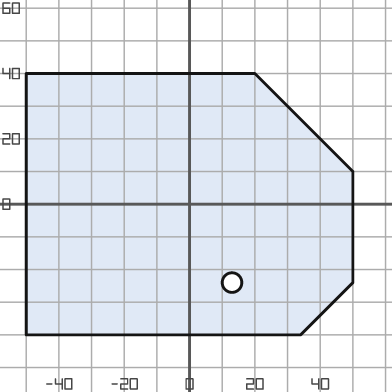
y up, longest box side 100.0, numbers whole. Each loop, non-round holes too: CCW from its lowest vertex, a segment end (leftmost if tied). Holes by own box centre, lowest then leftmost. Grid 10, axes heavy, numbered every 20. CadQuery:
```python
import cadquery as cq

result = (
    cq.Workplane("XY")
    .moveTo(-50.0, -40.0)
    .lineTo(34.0, -40.0)
    .lineTo(50.0, -24.0)
    .lineTo(50.0, 10.0)
    .lineTo(20.0, 40.0)
    .lineTo(-50.0, 40.0)
    .close()
    .moveTo(13.0, -24.0)
    .circle(3.0)
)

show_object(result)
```